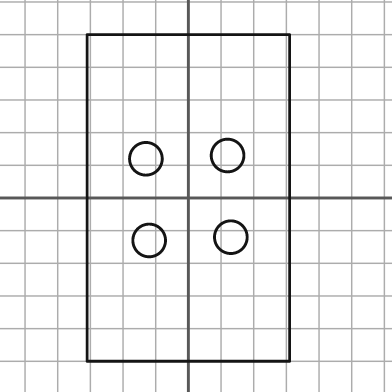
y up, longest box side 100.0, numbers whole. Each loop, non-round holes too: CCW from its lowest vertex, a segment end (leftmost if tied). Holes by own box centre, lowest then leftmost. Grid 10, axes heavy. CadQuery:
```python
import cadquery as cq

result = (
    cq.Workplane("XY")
    .moveTo(-31.0, -50.0)
    .lineTo(31.0, -50.0)
    .lineTo(31.0, 50.0)
    .lineTo(-31.0, 50.0)
    .close()
    .moveTo(-12.0, -13.0)
    .circle(5.0)
    .moveTo(13.0, -12.0)
    .circle(5.0)
    .moveTo(-13.0, 12.0)
    .circle(5.0)
    .moveTo(12.0, 13.0)
    .circle(5.0)
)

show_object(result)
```